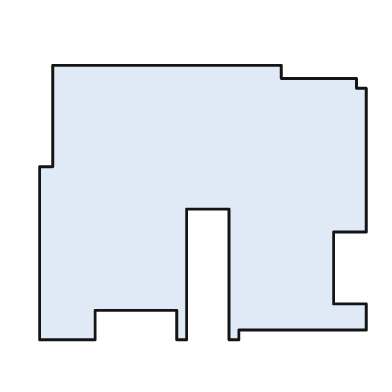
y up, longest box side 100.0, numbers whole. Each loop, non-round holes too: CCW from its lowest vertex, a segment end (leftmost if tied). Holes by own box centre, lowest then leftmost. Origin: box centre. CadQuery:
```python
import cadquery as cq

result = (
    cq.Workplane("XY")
    .moveTo(-50.0, -42.0)
    .lineTo(-33.0, -42.0)
    .lineTo(-33.0, -33.0)
    .lineTo(-8.0, -33.0)
    .lineTo(-8.0, -42.0)
    .lineTo(-5.0, -42.0)
    .lineTo(-5.0, -2.0)
    .lineTo(8.0, -2.0)
    .lineTo(8.0, -42.0)
    .lineTo(11.0, -42.0)
    .lineTo(11.0, -39.0)
    .lineTo(50.0, -39.0)
    .lineTo(50.0, -31.0)
    .lineTo(40.0, -31.0)
    .lineTo(40.0, -9.0)
    .lineTo(50.0, -9.0)
    .lineTo(50.0, 35.0)
    .lineTo(47.0, 35.0)
    .lineTo(47.0, 38.0)
    .lineTo(24.0, 38.0)
    .lineTo(24.0, 42.0)
    .lineTo(-46.0, 42.0)
    .lineTo(-46.0, 11.0)
    .lineTo(-50.0, 11.0)
    .close()
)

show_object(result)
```